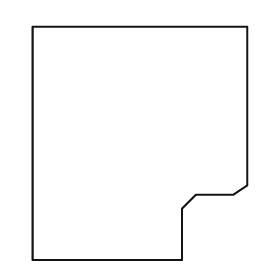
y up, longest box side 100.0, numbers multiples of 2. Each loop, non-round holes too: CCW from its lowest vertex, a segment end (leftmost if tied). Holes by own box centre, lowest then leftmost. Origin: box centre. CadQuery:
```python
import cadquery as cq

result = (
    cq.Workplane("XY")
    .moveTo(-46.0, -50.0)
    .lineTo(18.0, -50.0)
    .lineTo(18.0, -28.0)
    .lineTo(24.0, -22.0)
    .lineTo(40.0, -22.0)
    .lineTo(46.0, -18.0)
    .lineTo(46.0, 50.0)
    .lineTo(-46.0, 50.0)
    .close()
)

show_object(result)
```